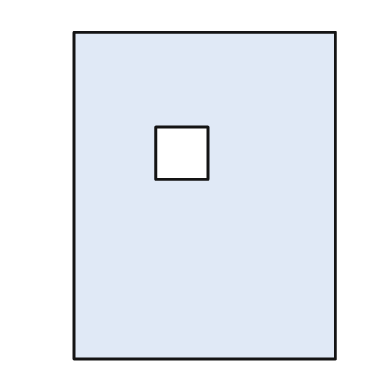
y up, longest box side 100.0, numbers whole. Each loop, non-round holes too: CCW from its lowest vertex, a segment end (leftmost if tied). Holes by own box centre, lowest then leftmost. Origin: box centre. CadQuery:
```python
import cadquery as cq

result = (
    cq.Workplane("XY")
    .moveTo(-40.0, -50.0)
    .lineTo(40.0, -50.0)
    .lineTo(40.0, 50.0)
    .lineTo(-40.0, 50.0)
    .close()
    .moveTo(-15.0, 5.0)
    .lineTo(1.0, 5.0)
    .lineTo(1.0, 21.0)
    .lineTo(-15.0, 21.0)
    .close()
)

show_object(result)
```